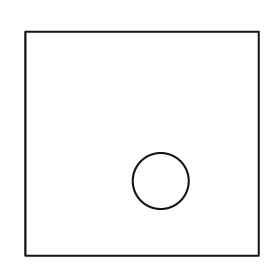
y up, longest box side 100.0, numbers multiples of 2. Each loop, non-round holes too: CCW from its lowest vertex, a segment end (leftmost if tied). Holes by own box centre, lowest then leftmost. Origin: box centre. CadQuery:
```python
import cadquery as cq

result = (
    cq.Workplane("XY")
    .moveTo(-50.0, -48.0)
    .lineTo(50.0, -48.0)
    .lineTo(50.0, 48.0)
    .lineTo(-50.0, 48.0)
    .close()
    .moveTo(8.0, -16.0)
    .circle(12.0)
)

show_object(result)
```